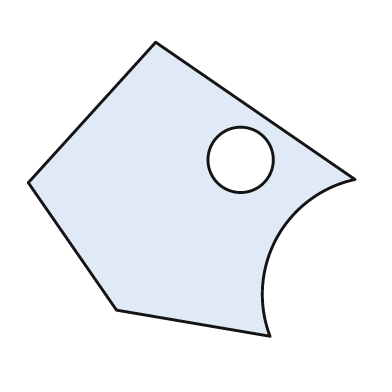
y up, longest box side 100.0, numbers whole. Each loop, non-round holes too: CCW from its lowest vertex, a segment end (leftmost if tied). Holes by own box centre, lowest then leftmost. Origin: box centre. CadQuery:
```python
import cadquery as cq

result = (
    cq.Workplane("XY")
    .moveTo(24.0, -45.0)
    .threePointArc((26.0, -15.0), (50.0, 3.0))
    .lineTo(-11.0, 45.0)
    .lineTo(-50.0, 2.0)
    .lineTo(-23.0, -37.0)
    .close()
    .moveTo(15.0, 9.0)
    .circle(10.0)
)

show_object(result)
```